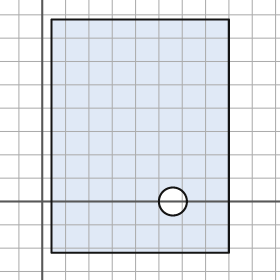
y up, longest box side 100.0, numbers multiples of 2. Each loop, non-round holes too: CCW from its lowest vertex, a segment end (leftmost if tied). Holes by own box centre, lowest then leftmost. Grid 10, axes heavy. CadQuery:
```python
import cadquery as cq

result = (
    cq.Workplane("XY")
    .moveTo(4.0, -22.0)
    .lineTo(80.0, -22.0)
    .lineTo(80.0, 78.0)
    .lineTo(4.0, 78.0)
    .close()
    .moveTo(56.0, 0.0)
    .circle(6.0)
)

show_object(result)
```